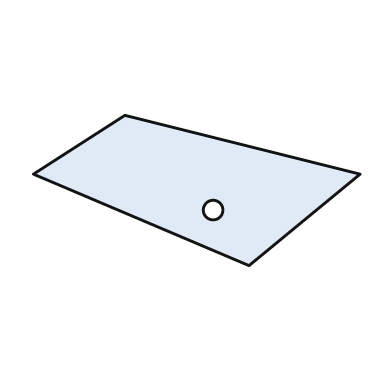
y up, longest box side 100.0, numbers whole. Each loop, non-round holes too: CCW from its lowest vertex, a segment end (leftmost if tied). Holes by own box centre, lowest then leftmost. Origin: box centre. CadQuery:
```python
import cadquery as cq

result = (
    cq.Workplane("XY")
    .moveTo(16.0, -23.0)
    .lineTo(50.0, 5.0)
    .lineTo(-22.0, 23.0)
    .lineTo(-50.0, 5.0)
    .close()
    .moveTo(5.0, -6.0)
    .circle(3.0)
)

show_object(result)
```